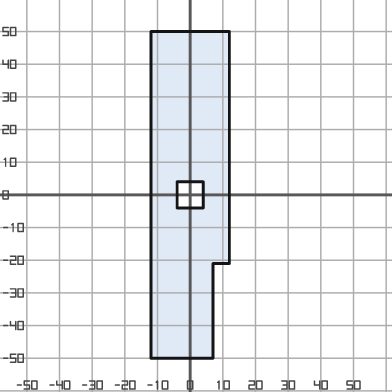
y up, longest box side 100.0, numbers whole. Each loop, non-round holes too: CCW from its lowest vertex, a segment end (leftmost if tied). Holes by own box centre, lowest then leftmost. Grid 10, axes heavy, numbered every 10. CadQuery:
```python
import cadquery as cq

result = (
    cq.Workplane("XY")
    .moveTo(-12.0, -50.0)
    .lineTo(7.0, -50.0)
    .lineTo(7.0, -21.0)
    .lineTo(12.0, -21.0)
    .lineTo(12.0, 50.0)
    .lineTo(-12.0, 50.0)
    .close()
    .moveTo(-4.0, -4.0)
    .lineTo(4.0, -4.0)
    .lineTo(4.0, 4.0)
    .lineTo(-4.0, 4.0)
    .close()
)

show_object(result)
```